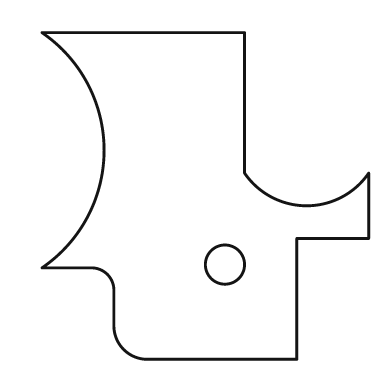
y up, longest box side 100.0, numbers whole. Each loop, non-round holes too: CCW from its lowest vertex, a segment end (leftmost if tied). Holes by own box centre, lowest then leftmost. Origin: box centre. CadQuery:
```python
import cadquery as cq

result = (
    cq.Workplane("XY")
    .moveTo(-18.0, -50.0)
    .lineTo(28.0, -50.0)
    .lineTo(28.0, -13.0)
    .lineTo(50.0, -13.0)
    .lineTo(50.0, 7.0)
    .threePointArc((31.0, -3.0), (12.0, 7.0))
    .lineTo(12.0, 50.0)
    .lineTo(-50.0, 50.0)
    .threePointArc((-31.0, 14.0), (-50.0, -22.0))
    .lineTo(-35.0, -22.0)
    .threePointArc((-30.0, -24.0), (-28.0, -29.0))
    .lineTo(-28.0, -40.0)
    .threePointArc((-25.0, -47.0), (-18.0, -50.0))
    .close()
    .moveTo(6.0, -21.0)
    .circle(6.0)
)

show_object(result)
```